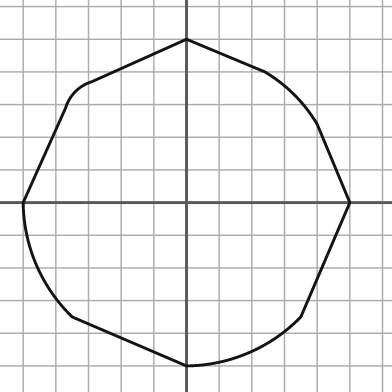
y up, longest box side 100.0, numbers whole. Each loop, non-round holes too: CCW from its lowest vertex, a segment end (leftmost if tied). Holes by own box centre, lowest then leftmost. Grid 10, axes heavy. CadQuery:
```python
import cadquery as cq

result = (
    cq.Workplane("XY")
    .moveTo(0.0, -50.0)
    .threePointArc((19.0, -46.0), (35.0, -35.0))
    .lineTo(50.0, 0.0)
    .lineTo(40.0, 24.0)
    .threePointArc((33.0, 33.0), (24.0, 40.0))
    .lineTo(0.0, 50.0)
    .lineTo(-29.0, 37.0)
    .threePointArc((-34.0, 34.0), (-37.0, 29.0))
    .lineTo(-50.0, 0.0)
    .threePointArc((-46.0, -19.0), (-35.0, -35.0))
    .close()
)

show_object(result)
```